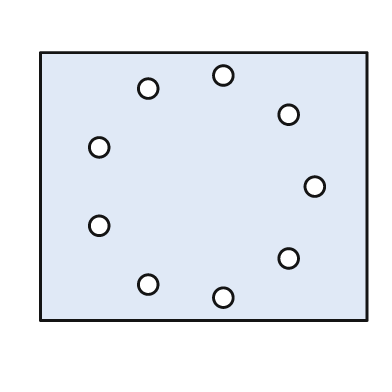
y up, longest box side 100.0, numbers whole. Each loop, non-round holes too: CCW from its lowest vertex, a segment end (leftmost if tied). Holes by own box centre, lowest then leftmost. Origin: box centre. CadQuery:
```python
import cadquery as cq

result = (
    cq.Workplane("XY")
    .moveTo(-50.0, -41.0)
    .lineTo(50.0, -41.0)
    .lineTo(50.0, 41.0)
    .lineTo(-50.0, 41.0)
    .close()
    .moveTo(6.0, -34.0)
    .circle(3.0)
    .moveTo(-17.0, -30.0)
    .circle(3.0)
    .moveTo(26.0, -22.0)
    .circle(3.0)
    .moveTo(-32.0, -12.0)
    .circle(3.0)
    .moveTo(34.0, 0.0)
    .circle(3.0)
    .moveTo(-32.0, 12.0)
    .circle(3.0)
    .moveTo(26.0, 22.0)
    .circle(3.0)
    .moveTo(-17.0, 30.0)
    .circle(3.0)
    .moveTo(6.0, 34.0)
    .circle(3.0)
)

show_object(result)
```